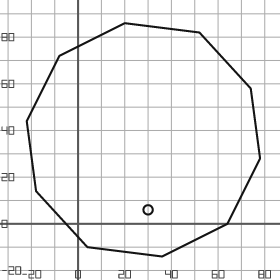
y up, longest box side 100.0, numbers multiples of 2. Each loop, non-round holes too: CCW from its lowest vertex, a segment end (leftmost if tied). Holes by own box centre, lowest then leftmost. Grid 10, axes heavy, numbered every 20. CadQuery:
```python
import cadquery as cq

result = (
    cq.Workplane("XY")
    .moveTo(36.0, -14.0)
    .lineTo(64.0, 0.0)
    .lineTo(78.0, 28.0)
    .lineTo(74.0, 58.0)
    .lineTo(52.0, 82.0)
    .lineTo(20.0, 86.0)
    .lineTo(-8.0, 72.0)
    .lineTo(-22.0, 44.0)
    .lineTo(-18.0, 14.0)
    .lineTo(4.0, -10.0)
    .close()
    .moveTo(30.0, 6.0)
    .circle(2.0)
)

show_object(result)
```